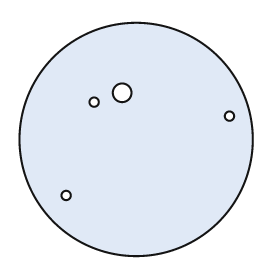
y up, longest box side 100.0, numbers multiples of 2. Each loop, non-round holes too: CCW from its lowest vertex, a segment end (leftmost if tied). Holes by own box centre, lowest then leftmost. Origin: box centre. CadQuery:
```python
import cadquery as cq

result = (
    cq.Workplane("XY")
    .moveTo(0.0, 0.0)
    .circle(50.0)
    .moveTo(-30.0, -24.0)
    .circle(2.0)
    .moveTo(40.0, 10.0)
    .circle(2.0)
    .moveTo(-18.0, 16.0)
    .circle(2.0)
    .moveTo(-6.0, 20.0)
    .circle(4.0)
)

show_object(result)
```